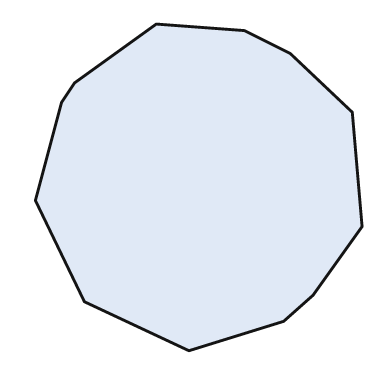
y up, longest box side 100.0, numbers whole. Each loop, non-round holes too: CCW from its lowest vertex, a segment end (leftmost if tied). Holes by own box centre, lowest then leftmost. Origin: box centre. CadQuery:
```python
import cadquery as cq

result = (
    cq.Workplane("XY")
    .moveTo(-3.0, -50.0)
    .lineTo(26.0, -41.0)
    .lineTo(35.0, -33.0)
    .lineTo(50.0, -12.0)
    .lineTo(47.0, 23.0)
    .lineTo(28.0, 41.0)
    .lineTo(14.0, 48.0)
    .lineTo(-13.0, 50.0)
    .lineTo(-38.0, 32.0)
    .lineTo(-42.0, 26.0)
    .lineTo(-50.0, -4.0)
    .lineTo(-35.0, -35.0)
    .close()
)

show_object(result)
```